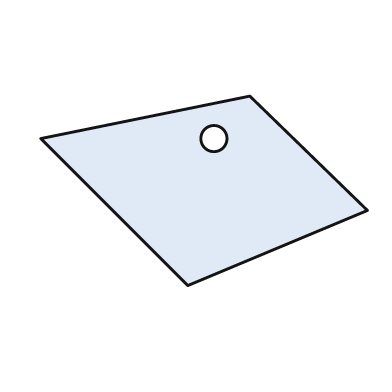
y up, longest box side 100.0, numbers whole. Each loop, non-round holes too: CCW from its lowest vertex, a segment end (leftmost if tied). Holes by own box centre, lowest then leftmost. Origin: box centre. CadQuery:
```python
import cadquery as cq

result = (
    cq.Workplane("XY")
    .moveTo(-5.0, -29.0)
    .lineTo(50.0, -6.0)
    .lineTo(14.0, 29.0)
    .lineTo(-50.0, 16.0)
    .close()
    .moveTo(3.0, 16.0)
    .circle(4.0)
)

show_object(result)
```